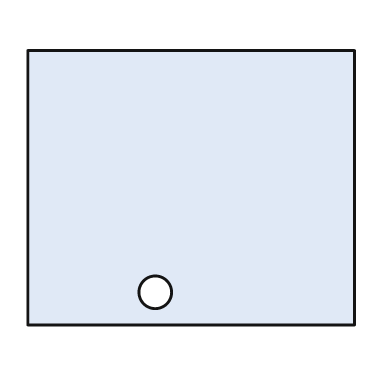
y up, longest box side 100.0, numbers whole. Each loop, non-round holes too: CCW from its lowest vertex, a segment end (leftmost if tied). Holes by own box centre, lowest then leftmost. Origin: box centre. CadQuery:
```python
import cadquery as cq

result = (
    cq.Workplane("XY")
    .moveTo(-50.0, -42.0)
    .lineTo(50.0, -42.0)
    .lineTo(50.0, 42.0)
    .lineTo(-50.0, 42.0)
    .close()
    .moveTo(-11.0, -32.0)
    .circle(5.0)
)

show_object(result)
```